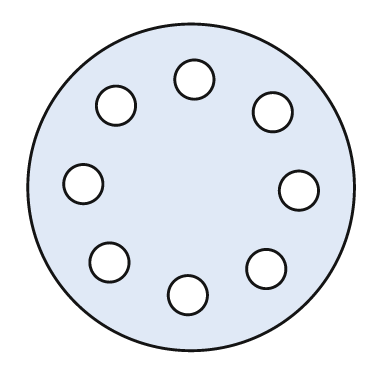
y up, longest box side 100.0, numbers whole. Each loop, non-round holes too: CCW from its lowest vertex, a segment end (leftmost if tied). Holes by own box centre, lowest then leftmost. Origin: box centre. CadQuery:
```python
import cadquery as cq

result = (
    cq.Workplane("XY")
    .moveTo(0.0, 0.0)
    .circle(50.0)
    .moveTo(-1.0, -33.0)
    .circle(6.0)
    .moveTo(23.0, -25.0)
    .circle(6.0)
    .moveTo(-25.0, -23.0)
    .circle(6.0)
    .moveTo(33.0, -1.0)
    .circle(6.0)
    .moveTo(-33.0, 1.0)
    .circle(6.0)
    .moveTo(25.0, 23.0)
    .circle(6.0)
    .moveTo(-23.0, 25.0)
    .circle(6.0)
    .moveTo(1.0, 33.0)
    .circle(6.0)
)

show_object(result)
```